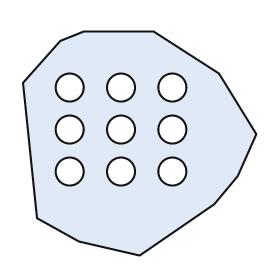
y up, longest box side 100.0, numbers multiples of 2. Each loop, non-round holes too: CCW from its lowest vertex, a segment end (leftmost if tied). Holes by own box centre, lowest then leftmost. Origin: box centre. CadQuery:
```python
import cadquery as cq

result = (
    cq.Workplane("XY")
    .moveTo(0.0, -48.0)
    .lineTo(32.0, -26.0)
    .lineTo(42.0, -14.0)
    .lineTo(50.0, 4.0)
    .lineTo(34.0, 30.0)
    .lineTo(6.0, 48.0)
    .lineTo(-24.0, 48.0)
    .lineTo(-34.0, 44.0)
    .lineTo(-50.0, 26.0)
    .lineTo(-44.0, -32.0)
    .lineTo(-26.0, -42.0)
    .close()
    .moveTo(-30.0, -12.0)
    .circle(6.0)
    .moveTo(-8.0, -12.0)
    .circle(6.0)
    .moveTo(14.0, -12.0)
    .circle(6.0)
    .moveTo(-30.0, 6.0)
    .circle(6.0)
    .moveTo(-8.0, 6.0)
    .circle(6.0)
    .moveTo(14.0, 6.0)
    .circle(6.0)
    .moveTo(-30.0, 24.0)
    .circle(6.0)
    .moveTo(-8.0, 24.0)
    .circle(6.0)
    .moveTo(14.0, 24.0)
    .circle(6.0)
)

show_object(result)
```